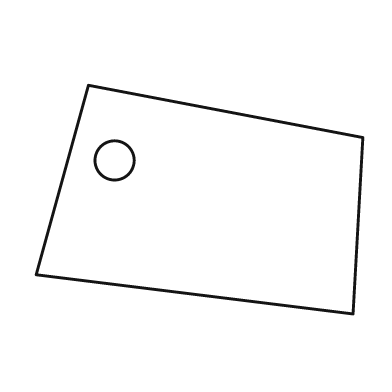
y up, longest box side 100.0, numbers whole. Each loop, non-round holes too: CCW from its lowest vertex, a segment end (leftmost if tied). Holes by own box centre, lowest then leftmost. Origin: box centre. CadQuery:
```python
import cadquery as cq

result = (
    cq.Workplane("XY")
    .moveTo(47.0, -35.0)
    .lineTo(50.0, 19.0)
    .lineTo(-34.0, 35.0)
    .lineTo(-50.0, -23.0)
    .close()
    .moveTo(-26.0, 12.0)
    .circle(6.0)
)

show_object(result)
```